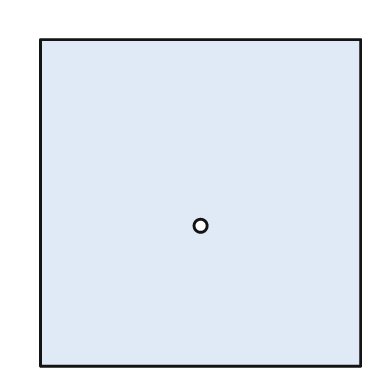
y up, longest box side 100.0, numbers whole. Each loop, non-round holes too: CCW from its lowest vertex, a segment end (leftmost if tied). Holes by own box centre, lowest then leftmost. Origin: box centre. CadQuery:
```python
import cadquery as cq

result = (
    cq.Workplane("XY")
    .moveTo(-49.0, -50.0)
    .lineTo(49.0, -50.0)
    .lineTo(49.0, 50.0)
    .lineTo(-49.0, 50.0)
    .close()
    .moveTo(0.0, -7.0)
    .circle(2.0)
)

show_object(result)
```